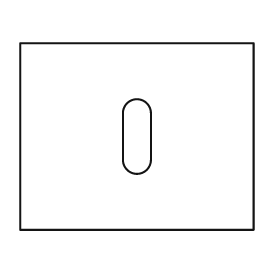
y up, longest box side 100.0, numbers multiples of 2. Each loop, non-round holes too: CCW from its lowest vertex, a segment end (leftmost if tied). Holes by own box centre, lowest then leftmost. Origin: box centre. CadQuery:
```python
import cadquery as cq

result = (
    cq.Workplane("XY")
    .moveTo(-50.0, -40.0)
    .lineTo(50.0, -40.0)
    .lineTo(50.0, 40.0)
    .lineTo(-50.0, 40.0)
    .close()
    .moveTo(-6.0, -10.0)
    .threePointArc((0.0, -16.0), (6.0, -10.0))
    .lineTo(6.0, 10.0)
    .threePointArc((0.0, 16.0), (-6.0, 10.0))
    .close()
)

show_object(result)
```